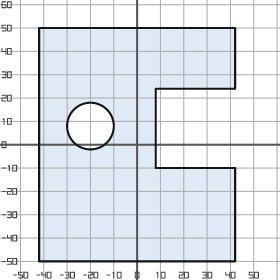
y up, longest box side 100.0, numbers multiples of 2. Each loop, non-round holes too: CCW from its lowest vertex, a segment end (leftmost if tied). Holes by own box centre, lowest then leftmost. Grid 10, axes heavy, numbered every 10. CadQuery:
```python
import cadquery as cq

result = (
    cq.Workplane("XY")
    .moveTo(-42.0, -50.0)
    .lineTo(42.0, -50.0)
    .lineTo(42.0, -10.0)
    .lineTo(8.0, -10.0)
    .lineTo(8.0, 24.0)
    .lineTo(42.0, 24.0)
    .lineTo(42.0, 50.0)
    .lineTo(-42.0, 50.0)
    .close()
    .moveTo(-20.0, 8.0)
    .circle(10.0)
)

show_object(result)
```